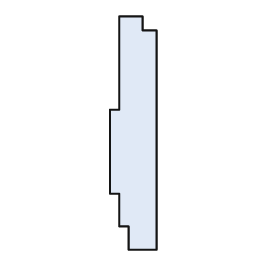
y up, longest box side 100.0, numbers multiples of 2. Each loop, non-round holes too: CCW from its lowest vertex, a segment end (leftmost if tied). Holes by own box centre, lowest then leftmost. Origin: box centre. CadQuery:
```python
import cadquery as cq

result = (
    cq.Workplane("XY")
    .moveTo(-2.0, -50.0)
    .lineTo(10.0, -50.0)
    .lineTo(10.0, 44.0)
    .lineTo(4.0, 44.0)
    .lineTo(4.0, 50.0)
    .lineTo(-6.0, 50.0)
    .lineTo(-6.0, 10.0)
    .lineTo(-10.0, 10.0)
    .lineTo(-10.0, -26.0)
    .lineTo(-6.0, -26.0)
    .lineTo(-6.0, -40.0)
    .lineTo(-2.0, -40.0)
    .close()
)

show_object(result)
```